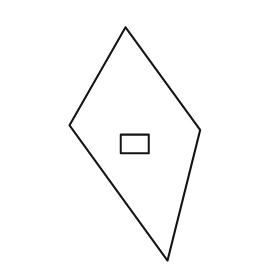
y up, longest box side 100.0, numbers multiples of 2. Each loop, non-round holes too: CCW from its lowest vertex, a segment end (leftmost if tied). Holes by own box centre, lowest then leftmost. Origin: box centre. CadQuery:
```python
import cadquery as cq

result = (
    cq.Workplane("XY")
    .moveTo(14.0, -50.0)
    .lineTo(28.0, 6.0)
    .lineTo(-4.0, 50.0)
    .lineTo(-28.0, 8.0)
    .close()
    .moveTo(-6.0, -4.0)
    .lineTo(6.0, -4.0)
    .lineTo(6.0, 4.0)
    .lineTo(-6.0, 4.0)
    .close()
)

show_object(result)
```